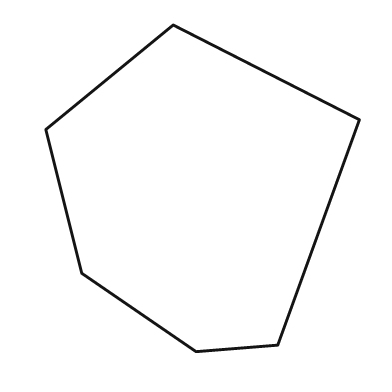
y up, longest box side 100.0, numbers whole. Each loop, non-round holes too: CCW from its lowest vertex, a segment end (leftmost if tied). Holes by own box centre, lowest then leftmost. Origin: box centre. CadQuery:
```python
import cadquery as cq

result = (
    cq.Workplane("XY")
    .moveTo(-2.0, -50.0)
    .lineTo(23.0, -48.0)
    .lineTo(48.0, 21.0)
    .lineTo(-9.0, 50.0)
    .lineTo(-48.0, 18.0)
    .lineTo(-37.0, -26.0)
    .close()
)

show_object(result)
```